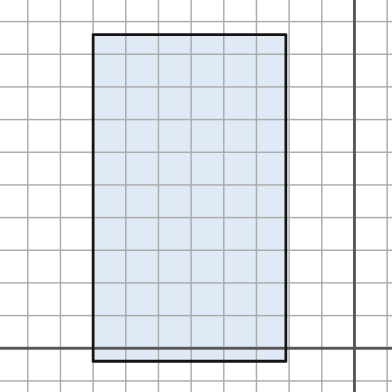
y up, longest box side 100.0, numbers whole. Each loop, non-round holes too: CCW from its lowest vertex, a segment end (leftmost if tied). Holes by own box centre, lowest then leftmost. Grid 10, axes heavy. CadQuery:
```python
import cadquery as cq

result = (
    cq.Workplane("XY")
    .moveTo(-80.0, -4.0)
    .lineTo(-21.0, -4.0)
    .lineTo(-21.0, 96.0)
    .lineTo(-80.0, 96.0)
    .close()
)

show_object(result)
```